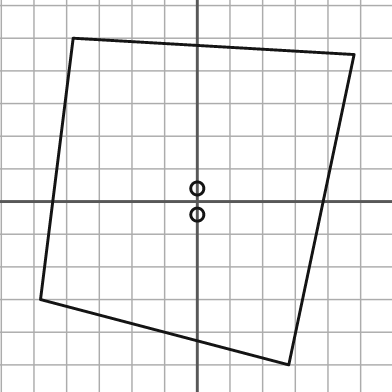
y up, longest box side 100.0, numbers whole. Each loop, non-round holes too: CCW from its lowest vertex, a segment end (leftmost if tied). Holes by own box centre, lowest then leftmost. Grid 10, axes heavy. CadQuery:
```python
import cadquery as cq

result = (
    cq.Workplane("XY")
    .moveTo(28.0, -50.0)
    .lineTo(48.0, 45.0)
    .lineTo(-38.0, 50.0)
    .lineTo(-48.0, -30.0)
    .close()
    .moveTo(0.0, -4.0)
    .circle(2.0)
    .moveTo(0.0, 4.0)
    .circle(2.0)
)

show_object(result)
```